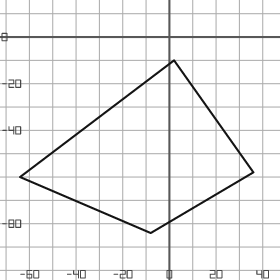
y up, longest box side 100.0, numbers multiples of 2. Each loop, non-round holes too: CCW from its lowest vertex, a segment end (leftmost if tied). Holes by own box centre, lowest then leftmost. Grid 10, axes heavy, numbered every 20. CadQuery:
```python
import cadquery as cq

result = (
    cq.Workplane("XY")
    .moveTo(-8.0, -84.0)
    .lineTo(36.0, -58.0)
    .lineTo(2.0, -10.0)
    .lineTo(-64.0, -60.0)
    .close()
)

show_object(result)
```